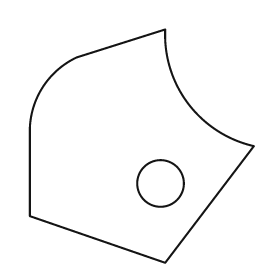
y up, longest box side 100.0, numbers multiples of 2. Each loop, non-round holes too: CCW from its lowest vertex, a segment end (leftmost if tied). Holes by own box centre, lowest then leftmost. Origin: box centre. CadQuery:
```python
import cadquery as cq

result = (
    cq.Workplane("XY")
    .moveTo(10.0, -50.0)
    .lineTo(48.0, 0.0)
    .threePointArc((20.0, 18.0), (10.0, 50.0))
    .lineTo(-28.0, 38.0)
    .threePointArc((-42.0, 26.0), (-48.0, 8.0))
    .lineTo(-48.0, -30.0)
    .close()
    .moveTo(8.0, -16.0)
    .circle(10.0)
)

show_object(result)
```